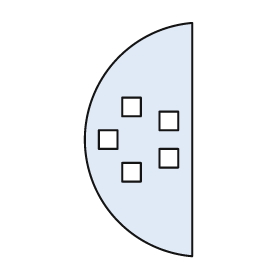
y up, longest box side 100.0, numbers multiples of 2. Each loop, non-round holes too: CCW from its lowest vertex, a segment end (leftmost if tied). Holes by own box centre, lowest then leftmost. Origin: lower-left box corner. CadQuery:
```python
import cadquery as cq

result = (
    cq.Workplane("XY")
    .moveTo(46.0, 0.0)
    .lineTo(46.0, 100.0)
    .threePointArc((0.0, 50.0), (46.0, 0.0))
    .close()
    .moveTo(16.0, 32.0)
    .lineTo(24.0, 32.0)
    .lineTo(24.0, 40.0)
    .lineTo(16.0, 40.0)
    .close()
    .moveTo(32.0, 38.0)
    .lineTo(40.0, 38.0)
    .lineTo(40.0, 46.0)
    .lineTo(32.0, 46.0)
    .close()
    .moveTo(6.0, 46.0)
    .lineTo(14.0, 46.0)
    .lineTo(14.0, 54.0)
    .lineTo(6.0, 54.0)
    .close()
    .moveTo(32.0, 54.0)
    .lineTo(40.0, 54.0)
    .lineTo(40.0, 62.0)
    .lineTo(32.0, 62.0)
    .close()
    .moveTo(16.0, 60.0)
    .lineTo(24.0, 60.0)
    .lineTo(24.0, 68.0)
    .lineTo(16.0, 68.0)
    .close()
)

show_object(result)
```